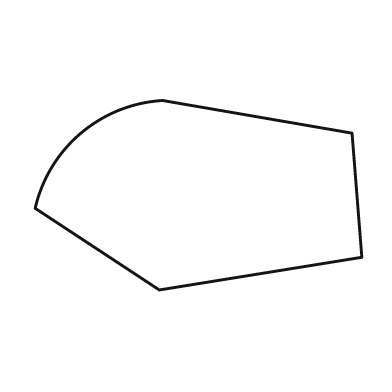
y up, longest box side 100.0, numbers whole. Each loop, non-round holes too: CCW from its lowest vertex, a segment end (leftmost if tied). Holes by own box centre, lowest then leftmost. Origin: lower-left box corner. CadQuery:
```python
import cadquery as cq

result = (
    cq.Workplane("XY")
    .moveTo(38.0, 0.0)
    .lineTo(100.0, 10.0)
    .lineTo(97.0, 48.0)
    .lineTo(39.0, 58.0)
    .threePointArc((14.0, 48.0), (0.0, 25.0))
    .close()
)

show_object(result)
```